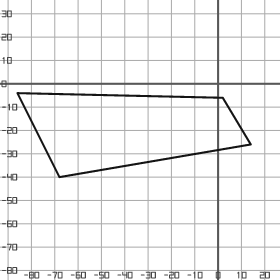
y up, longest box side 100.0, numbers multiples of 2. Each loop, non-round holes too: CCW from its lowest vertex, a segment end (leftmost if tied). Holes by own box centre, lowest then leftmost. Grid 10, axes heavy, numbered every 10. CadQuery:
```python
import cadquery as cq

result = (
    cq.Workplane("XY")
    .moveTo(-68.0, -40.0)
    .lineTo(14.0, -26.0)
    .lineTo(2.0, -6.0)
    .lineTo(-86.0, -4.0)
    .close()
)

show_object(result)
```